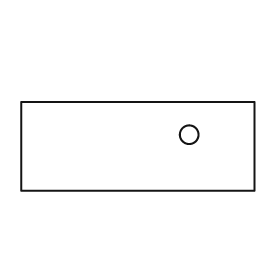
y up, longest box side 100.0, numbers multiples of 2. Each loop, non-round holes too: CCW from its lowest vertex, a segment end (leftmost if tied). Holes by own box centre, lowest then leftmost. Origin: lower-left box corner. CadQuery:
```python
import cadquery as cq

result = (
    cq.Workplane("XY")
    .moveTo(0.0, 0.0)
    .lineTo(100.0, 0.0)
    .lineTo(100.0, 38.0)
    .lineTo(0.0, 38.0)
    .close()
    .moveTo(72.0, 24.0)
    .circle(4.0)
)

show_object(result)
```